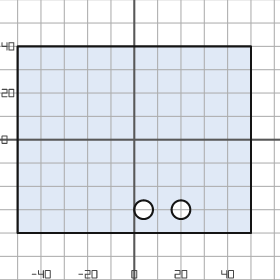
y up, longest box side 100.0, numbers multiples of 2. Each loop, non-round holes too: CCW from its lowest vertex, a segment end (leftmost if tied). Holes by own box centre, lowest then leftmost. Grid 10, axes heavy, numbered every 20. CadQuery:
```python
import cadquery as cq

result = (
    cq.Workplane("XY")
    .moveTo(-50.0, -40.0)
    .lineTo(50.0, -40.0)
    .lineTo(50.0, 40.0)
    .lineTo(-50.0, 40.0)
    .close()
    .moveTo(4.0, -30.0)
    .circle(4.0)
    .moveTo(20.0, -30.0)
    .circle(4.0)
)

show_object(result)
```